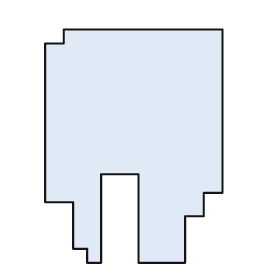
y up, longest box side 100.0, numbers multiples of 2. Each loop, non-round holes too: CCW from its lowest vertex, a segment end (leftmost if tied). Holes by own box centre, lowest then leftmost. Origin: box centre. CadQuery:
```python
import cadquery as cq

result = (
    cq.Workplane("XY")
    .moveTo(-20.0, -50.0)
    .lineTo(-14.0, -50.0)
    .lineTo(-14.0, -12.0)
    .lineTo(2.0, -12.0)
    .lineTo(2.0, -50.0)
    .lineTo(22.0, -50.0)
    .lineTo(22.0, -30.0)
    .lineTo(30.0, -30.0)
    .lineTo(30.0, -20.0)
    .lineTo(38.0, -20.0)
    .lineTo(38.0, 50.0)
    .lineTo(-30.0, 50.0)
    .lineTo(-30.0, 44.0)
    .lineTo(-38.0, 44.0)
    .lineTo(-38.0, -24.0)
    .lineTo(-26.0, -24.0)
    .lineTo(-26.0, -44.0)
    .lineTo(-20.0, -44.0)
    .close()
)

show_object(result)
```